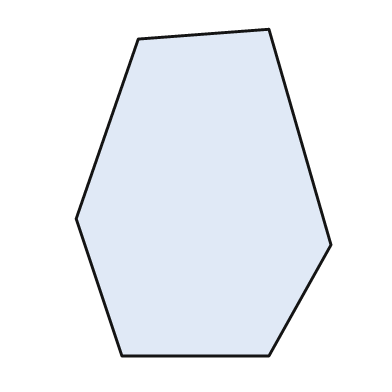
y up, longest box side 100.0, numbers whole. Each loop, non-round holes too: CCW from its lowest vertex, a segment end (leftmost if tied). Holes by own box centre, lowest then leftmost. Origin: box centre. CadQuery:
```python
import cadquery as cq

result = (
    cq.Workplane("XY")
    .moveTo(-25.0, -50.0)
    .lineTo(20.0, -50.0)
    .lineTo(39.0, -16.0)
    .lineTo(20.0, 50.0)
    .lineTo(-20.0, 47.0)
    .lineTo(-39.0, -8.0)
    .close()
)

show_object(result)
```